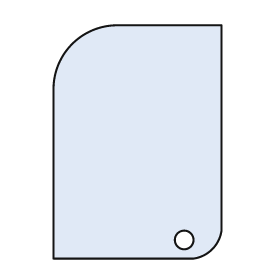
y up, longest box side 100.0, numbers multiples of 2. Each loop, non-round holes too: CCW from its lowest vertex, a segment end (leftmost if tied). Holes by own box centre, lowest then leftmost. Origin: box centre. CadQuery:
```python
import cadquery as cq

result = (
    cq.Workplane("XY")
    .moveTo(-36.0, -50.0)
    .lineTo(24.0, -50.0)
    .threePointArc((32.0, -46.0), (36.0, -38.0))
    .lineTo(36.0, 50.0)
    .lineTo(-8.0, 50.0)
    .threePointArc((-28.0, 42.0), (-36.0, 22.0))
    .close()
    .moveTo(20.0, -42.0)
    .circle(4.0)
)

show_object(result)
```